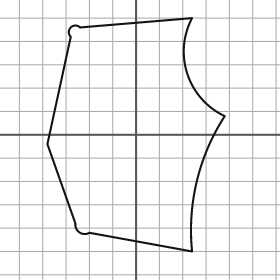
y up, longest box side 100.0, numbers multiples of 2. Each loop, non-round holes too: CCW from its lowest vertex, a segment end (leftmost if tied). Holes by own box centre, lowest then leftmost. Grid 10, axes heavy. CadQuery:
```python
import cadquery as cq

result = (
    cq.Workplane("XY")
    .moveTo(24.0, -50.0)
    .threePointArc((26.0, -20.0), (38.0, 8.0))
    .threePointArc((22.0, 26.0), (24.0, 50.0))
    .lineTo(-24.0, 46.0)
    .threePointArc((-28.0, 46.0), (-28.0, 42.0))
    .lineTo(-38.0, -4.0)
    .lineTo(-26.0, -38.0)
    .threePointArc((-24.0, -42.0), (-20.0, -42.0))
    .close()
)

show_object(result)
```